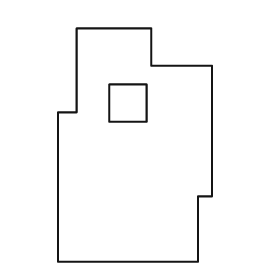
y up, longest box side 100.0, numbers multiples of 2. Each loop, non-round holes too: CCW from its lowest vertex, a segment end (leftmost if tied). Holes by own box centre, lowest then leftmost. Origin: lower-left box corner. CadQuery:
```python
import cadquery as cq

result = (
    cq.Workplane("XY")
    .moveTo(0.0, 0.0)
    .lineTo(60.0, 0.0)
    .lineTo(60.0, 28.0)
    .lineTo(66.0, 28.0)
    .lineTo(66.0, 84.0)
    .lineTo(40.0, 84.0)
    .lineTo(40.0, 100.0)
    .lineTo(8.0, 100.0)
    .lineTo(8.0, 64.0)
    .lineTo(0.0, 64.0)
    .close()
    .moveTo(22.0, 60.0)
    .lineTo(38.0, 60.0)
    .lineTo(38.0, 76.0)
    .lineTo(22.0, 76.0)
    .close()
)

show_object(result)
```